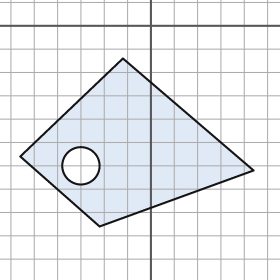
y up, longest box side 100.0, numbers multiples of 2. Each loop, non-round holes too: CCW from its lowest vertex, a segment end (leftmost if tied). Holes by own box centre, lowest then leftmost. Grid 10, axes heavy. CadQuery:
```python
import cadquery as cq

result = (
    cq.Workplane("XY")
    .moveTo(-22.0, -86.0)
    .lineTo(44.0, -62.0)
    .lineTo(-12.0, -14.0)
    .lineTo(-56.0, -56.0)
    .close()
    .moveTo(-30.0, -60.0)
    .circle(8.0)
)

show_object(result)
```